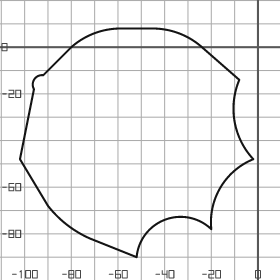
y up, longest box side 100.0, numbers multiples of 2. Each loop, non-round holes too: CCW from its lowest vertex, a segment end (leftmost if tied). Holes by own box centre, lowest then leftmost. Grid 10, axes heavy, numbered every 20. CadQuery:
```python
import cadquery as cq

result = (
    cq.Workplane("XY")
    .moveTo(-52.0, -90.0)
    .threePointArc((-40.0, -74.0), (-20.0, -78.0))
    .threePointArc((-16.0, -60.0), (-2.0, -48.0))
    .threePointArc((-10.0, -32.0), (-8.0, -14.0))
    .lineTo(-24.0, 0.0)
    .threePointArc((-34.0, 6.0), (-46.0, 8.0))
    .lineTo(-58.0, 8.0)
    .threePointArc((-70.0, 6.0), (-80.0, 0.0))
    .lineTo(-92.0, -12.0)
    .threePointArc((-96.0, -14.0), (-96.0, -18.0))
    .lineTo(-102.0, -48.0)
    .lineTo(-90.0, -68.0)
    .threePointArc((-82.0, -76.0), (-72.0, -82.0))
    .close()
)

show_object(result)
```